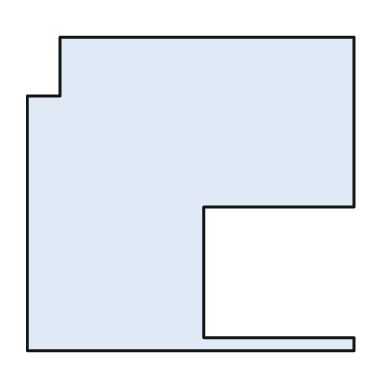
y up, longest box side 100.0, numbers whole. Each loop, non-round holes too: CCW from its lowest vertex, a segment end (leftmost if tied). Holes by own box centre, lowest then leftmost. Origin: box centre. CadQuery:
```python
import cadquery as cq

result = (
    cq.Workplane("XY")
    .moveTo(-50.0, -48.0)
    .lineTo(50.0, -48.0)
    .lineTo(50.0, -44.0)
    .lineTo(4.0, -44.0)
    .lineTo(4.0, -4.0)
    .lineTo(50.0, -4.0)
    .lineTo(50.0, 48.0)
    .lineTo(-40.0, 48.0)
    .lineTo(-40.0, 30.0)
    .lineTo(-50.0, 30.0)
    .close()
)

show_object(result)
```